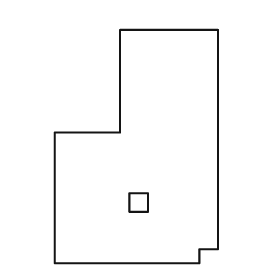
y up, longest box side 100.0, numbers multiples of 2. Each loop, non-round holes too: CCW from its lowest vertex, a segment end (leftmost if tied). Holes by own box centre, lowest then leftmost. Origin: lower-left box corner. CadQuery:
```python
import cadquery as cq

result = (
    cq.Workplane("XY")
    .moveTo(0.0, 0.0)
    .lineTo(62.0, 0.0)
    .lineTo(62.0, 6.0)
    .lineTo(70.0, 6.0)
    .lineTo(70.0, 100.0)
    .lineTo(28.0, 100.0)
    .lineTo(28.0, 56.0)
    .lineTo(0.0, 56.0)
    .close()
    .moveTo(32.0, 22.0)
    .lineTo(40.0, 22.0)
    .lineTo(40.0, 30.0)
    .lineTo(32.0, 30.0)
    .close()
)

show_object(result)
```